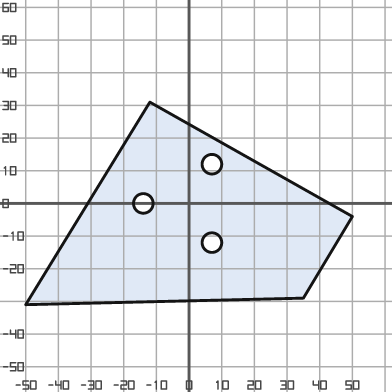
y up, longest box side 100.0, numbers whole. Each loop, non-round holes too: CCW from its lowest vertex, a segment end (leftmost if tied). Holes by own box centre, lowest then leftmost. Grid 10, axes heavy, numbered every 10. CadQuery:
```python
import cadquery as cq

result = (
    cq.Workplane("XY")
    .moveTo(-50.0, -31.0)
    .lineTo(35.0, -29.0)
    .lineTo(50.0, -4.0)
    .lineTo(-12.0, 31.0)
    .close()
    .moveTo(7.0, -12.0)
    .circle(3.0)
    .moveTo(-14.0, 0.0)
    .circle(3.0)
    .moveTo(7.0, 12.0)
    .circle(3.0)
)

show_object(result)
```